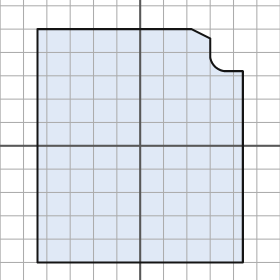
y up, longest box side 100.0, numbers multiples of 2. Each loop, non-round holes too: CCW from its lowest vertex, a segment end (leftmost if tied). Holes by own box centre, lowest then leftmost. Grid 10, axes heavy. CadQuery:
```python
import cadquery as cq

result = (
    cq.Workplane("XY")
    .moveTo(-44.0, -50.0)
    .lineTo(44.0, -50.0)
    .lineTo(44.0, 32.0)
    .lineTo(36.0, 32.0)
    .threePointArc((32.0, 34.0), (30.0, 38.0))
    .lineTo(30.0, 46.0)
    .lineTo(22.0, 50.0)
    .lineTo(-44.0, 50.0)
    .close()
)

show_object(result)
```